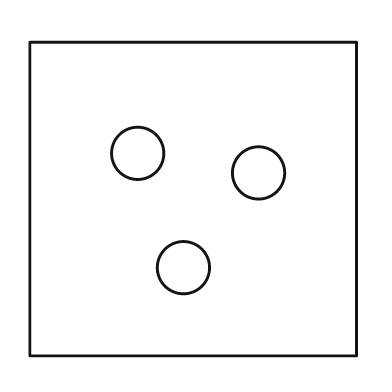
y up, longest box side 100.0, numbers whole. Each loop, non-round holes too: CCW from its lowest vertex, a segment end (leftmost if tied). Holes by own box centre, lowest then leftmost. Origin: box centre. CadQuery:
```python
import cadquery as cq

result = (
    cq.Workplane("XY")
    .moveTo(-50.0, -48.0)
    .lineTo(50.0, -48.0)
    .lineTo(50.0, 48.0)
    .lineTo(-50.0, 48.0)
    .close()
    .moveTo(-3.0, -21.0)
    .circle(8.0)
    .moveTo(20.0, 8.0)
    .circle(8.0)
    .moveTo(-17.0, 14.0)
    .circle(8.0)
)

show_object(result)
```